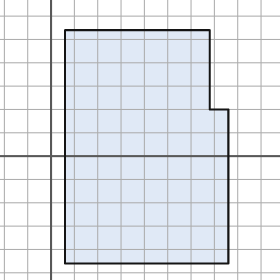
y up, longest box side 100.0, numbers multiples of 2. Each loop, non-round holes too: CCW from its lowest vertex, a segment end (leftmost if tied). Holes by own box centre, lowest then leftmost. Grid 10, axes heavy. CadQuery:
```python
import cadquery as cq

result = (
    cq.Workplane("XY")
    .moveTo(6.0, -46.0)
    .lineTo(76.0, -46.0)
    .lineTo(76.0, 20.0)
    .lineTo(68.0, 20.0)
    .lineTo(68.0, 54.0)
    .lineTo(6.0, 54.0)
    .close()
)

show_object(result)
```